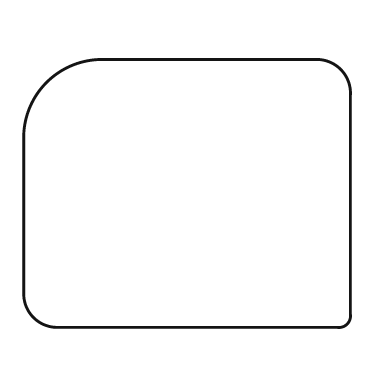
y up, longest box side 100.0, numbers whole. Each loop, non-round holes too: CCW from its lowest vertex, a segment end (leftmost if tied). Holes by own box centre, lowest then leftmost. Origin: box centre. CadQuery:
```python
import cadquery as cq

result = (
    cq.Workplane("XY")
    .moveTo(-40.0, -41.0)
    .lineTo(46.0, -41.0)
    .threePointArc((49.0, -40.0), (50.0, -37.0))
    .lineTo(50.0, 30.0)
    .threePointArc((47.0, 38.0), (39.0, 41.0))
    .lineTo(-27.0, 41.0)
    .threePointArc((-43.0, 34.0), (-50.0, 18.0))
    .lineTo(-50.0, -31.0)
    .threePointArc((-47.0, -38.0), (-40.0, -41.0))
    .close()
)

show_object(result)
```